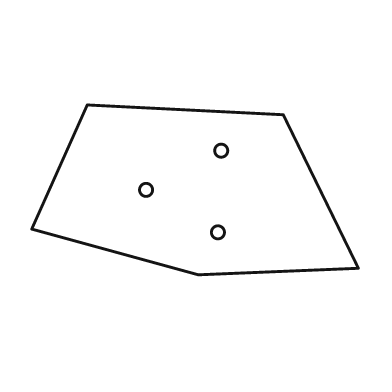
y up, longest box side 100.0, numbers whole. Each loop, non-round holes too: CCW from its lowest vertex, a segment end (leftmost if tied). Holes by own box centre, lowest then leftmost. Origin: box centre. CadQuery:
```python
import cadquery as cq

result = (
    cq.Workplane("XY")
    .moveTo(1.0, -26.0)
    .lineTo(50.0, -24.0)
    .lineTo(27.0, 23.0)
    .lineTo(-33.0, 26.0)
    .lineTo(-50.0, -12.0)
    .close()
    .moveTo(7.0, -13.0)
    .circle(2.0)
    .moveTo(-15.0, 0.0)
    .circle(2.0)
    .moveTo(8.0, 12.0)
    .circle(2.0)
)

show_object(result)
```